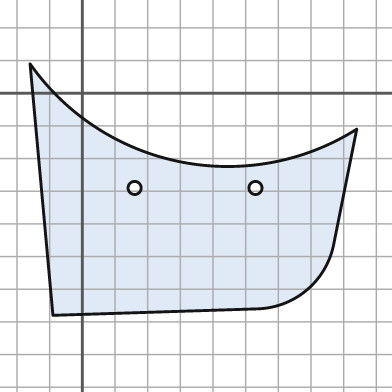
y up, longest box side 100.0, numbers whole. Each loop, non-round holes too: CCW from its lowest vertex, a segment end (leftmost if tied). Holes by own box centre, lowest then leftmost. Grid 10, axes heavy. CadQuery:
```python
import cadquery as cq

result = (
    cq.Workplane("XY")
    .moveTo(-9.0, -68.0)
    .lineTo(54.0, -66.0)
    .threePointArc((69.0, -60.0), (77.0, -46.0))
    .lineTo(84.0, -11.0)
    .threePointArc((30.0, -21.0), (-16.0, 9.0))
    .close()
    .moveTo(16.0, -29.0)
    .circle(2.0)
    .moveTo(53.0, -29.0)
    .circle(2.0)
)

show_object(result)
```